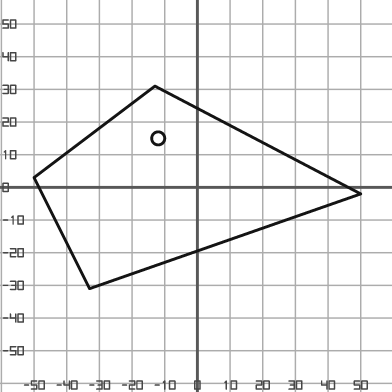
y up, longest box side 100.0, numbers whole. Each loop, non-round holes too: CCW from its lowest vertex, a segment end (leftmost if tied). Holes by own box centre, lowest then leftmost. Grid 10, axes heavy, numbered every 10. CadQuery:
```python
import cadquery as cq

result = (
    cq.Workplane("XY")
    .moveTo(-33.0, -31.0)
    .lineTo(50.0, -2.0)
    .lineTo(-13.0, 31.0)
    .lineTo(-50.0, 3.0)
    .close()
    .moveTo(-12.0, 15.0)
    .circle(2.0)
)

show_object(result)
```